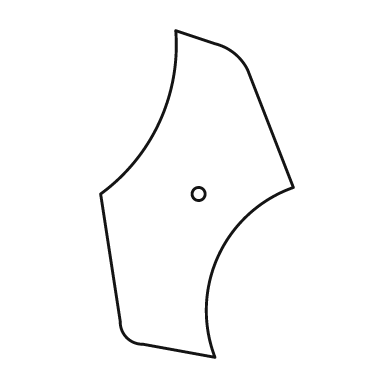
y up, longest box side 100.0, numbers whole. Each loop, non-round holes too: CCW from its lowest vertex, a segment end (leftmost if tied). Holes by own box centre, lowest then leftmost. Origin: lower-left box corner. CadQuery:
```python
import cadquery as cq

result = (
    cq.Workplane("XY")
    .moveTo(35.0, 0.0)
    .threePointArc((36.0, 31.0), (59.0, 52.0))
    .lineTo(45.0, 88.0)
    .threePointArc((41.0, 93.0), (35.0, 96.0))
    .lineTo(23.0, 100.0)
    .threePointArc((18.0, 72.0), (0.0, 50.0))
    .lineTo(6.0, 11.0)
    .threePointArc((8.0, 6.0), (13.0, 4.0))
    .close()
    .moveTo(30.0, 50.0)
    .circle(2.0)
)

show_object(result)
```